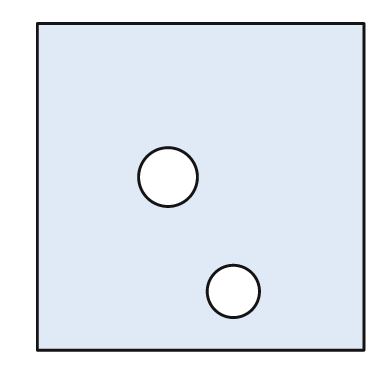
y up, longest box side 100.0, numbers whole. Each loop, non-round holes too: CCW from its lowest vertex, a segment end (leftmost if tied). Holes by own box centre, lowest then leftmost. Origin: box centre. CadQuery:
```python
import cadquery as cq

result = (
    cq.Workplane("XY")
    .moveTo(-50.0, -50.0)
    .lineTo(50.0, -50.0)
    .lineTo(50.0, 50.0)
    .lineTo(-50.0, 50.0)
    .close()
    .moveTo(10.0, -32.0)
    .circle(8.0)
    .moveTo(-10.0, 3.0)
    .circle(9.0)
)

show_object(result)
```